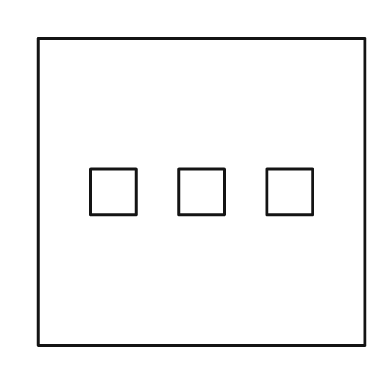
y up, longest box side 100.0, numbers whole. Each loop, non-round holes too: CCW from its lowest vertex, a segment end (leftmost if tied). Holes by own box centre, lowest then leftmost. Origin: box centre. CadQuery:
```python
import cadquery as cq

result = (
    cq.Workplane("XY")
    .moveTo(-50.0, -47.0)
    .lineTo(50.0, -47.0)
    .lineTo(50.0, 47.0)
    .lineTo(-50.0, 47.0)
    .close()
    .moveTo(-34.0, -7.0)
    .lineTo(-20.0, -7.0)
    .lineTo(-20.0, 7.0)
    .lineTo(-34.0, 7.0)
    .close()
    .moveTo(-7.0, -7.0)
    .lineTo(7.0, -7.0)
    .lineTo(7.0, 7.0)
    .lineTo(-7.0, 7.0)
    .close()
    .moveTo(20.0, -7.0)
    .lineTo(34.0, -7.0)
    .lineTo(34.0, 7.0)
    .lineTo(20.0, 7.0)
    .close()
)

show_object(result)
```